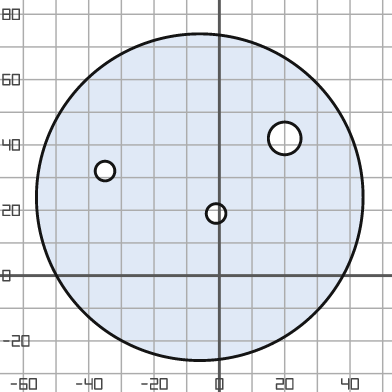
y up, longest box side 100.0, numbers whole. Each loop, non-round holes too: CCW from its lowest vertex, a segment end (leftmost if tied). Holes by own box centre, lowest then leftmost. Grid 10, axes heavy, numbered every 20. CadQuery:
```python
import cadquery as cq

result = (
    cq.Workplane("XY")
    .moveTo(-6.0, 24.0)
    .circle(50.0)
    .moveTo(-1.0, 19.0)
    .circle(3.0)
    .moveTo(-35.0, 32.0)
    .circle(3.0)
    .moveTo(20.0, 42.0)
    .circle(5.0)
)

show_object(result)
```